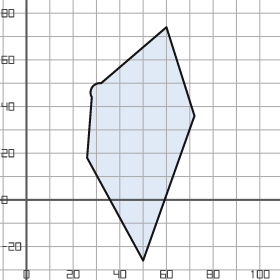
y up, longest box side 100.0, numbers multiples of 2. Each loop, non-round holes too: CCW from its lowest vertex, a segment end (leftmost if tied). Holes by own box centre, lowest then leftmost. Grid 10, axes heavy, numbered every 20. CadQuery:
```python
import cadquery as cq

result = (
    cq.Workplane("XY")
    .moveTo(50.0, -26.0)
    .lineTo(72.0, 36.0)
    .lineTo(60.0, 74.0)
    .lineTo(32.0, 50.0)
    .threePointArc((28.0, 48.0), (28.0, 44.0))
    .lineTo(26.0, 18.0)
    .close()
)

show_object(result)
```